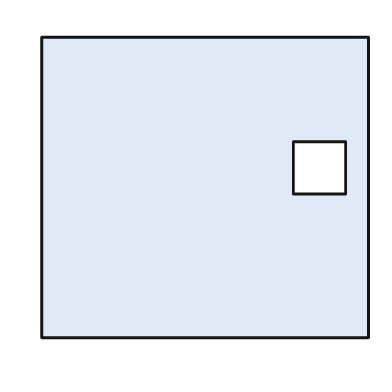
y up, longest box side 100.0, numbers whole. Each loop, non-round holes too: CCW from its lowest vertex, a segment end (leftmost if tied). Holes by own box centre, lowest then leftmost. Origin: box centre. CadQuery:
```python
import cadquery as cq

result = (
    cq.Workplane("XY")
    .moveTo(-50.0, -46.0)
    .lineTo(50.0, -46.0)
    .lineTo(50.0, 46.0)
    .lineTo(-50.0, 46.0)
    .close()
    .moveTo(27.0, -2.0)
    .lineTo(43.0, -2.0)
    .lineTo(43.0, 14.0)
    .lineTo(27.0, 14.0)
    .close()
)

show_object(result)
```